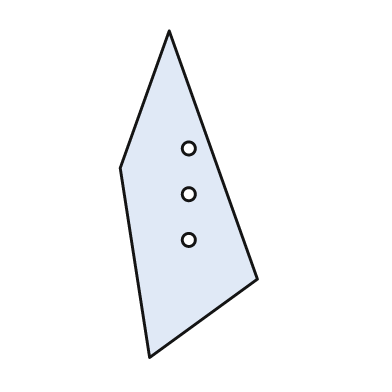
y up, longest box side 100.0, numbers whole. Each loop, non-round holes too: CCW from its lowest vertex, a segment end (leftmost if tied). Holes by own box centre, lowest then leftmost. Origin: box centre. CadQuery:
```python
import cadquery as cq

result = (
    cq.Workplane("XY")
    .moveTo(-12.0, -50.0)
    .lineTo(21.0, -26.0)
    .lineTo(-6.0, 50.0)
    .lineTo(-21.0, 8.0)
    .close()
    .moveTo(0.0, -14.0)
    .circle(2.0)
    .moveTo(0.0, 0.0)
    .circle(2.0)
    .moveTo(0.0, 14.0)
    .circle(2.0)
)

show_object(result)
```